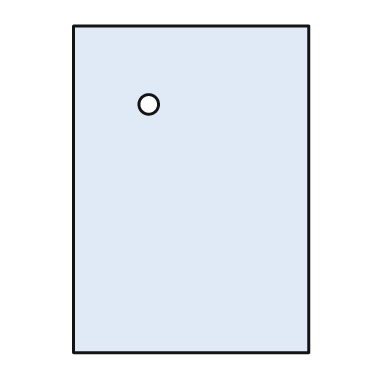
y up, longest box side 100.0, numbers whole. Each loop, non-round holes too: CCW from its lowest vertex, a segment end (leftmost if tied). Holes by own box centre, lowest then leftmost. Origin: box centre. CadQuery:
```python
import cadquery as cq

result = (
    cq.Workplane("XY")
    .moveTo(-36.0, -50.0)
    .lineTo(36.0, -50.0)
    .lineTo(36.0, 50.0)
    .lineTo(-36.0, 50.0)
    .close()
    .moveTo(-13.0, 26.0)
    .circle(3.0)
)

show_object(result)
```